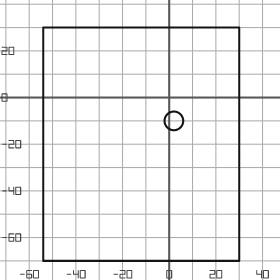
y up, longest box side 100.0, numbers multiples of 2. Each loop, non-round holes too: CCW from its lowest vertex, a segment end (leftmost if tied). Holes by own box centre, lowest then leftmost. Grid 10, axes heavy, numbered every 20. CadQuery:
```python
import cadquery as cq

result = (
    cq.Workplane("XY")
    .moveTo(-54.0, -70.0)
    .lineTo(30.0, -70.0)
    .lineTo(30.0, 30.0)
    .lineTo(-54.0, 30.0)
    .close()
    .moveTo(2.0, -10.0)
    .circle(4.0)
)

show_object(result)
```